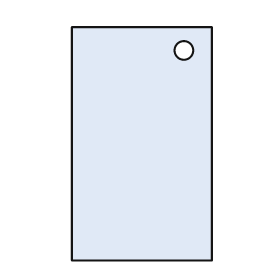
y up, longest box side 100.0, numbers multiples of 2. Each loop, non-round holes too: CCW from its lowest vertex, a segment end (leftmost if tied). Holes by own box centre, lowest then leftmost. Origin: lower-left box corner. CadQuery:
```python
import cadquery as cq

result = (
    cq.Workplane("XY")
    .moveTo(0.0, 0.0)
    .lineTo(60.0, 0.0)
    .lineTo(60.0, 100.0)
    .lineTo(0.0, 100.0)
    .close()
    .moveTo(48.0, 90.0)
    .circle(4.0)
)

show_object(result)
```